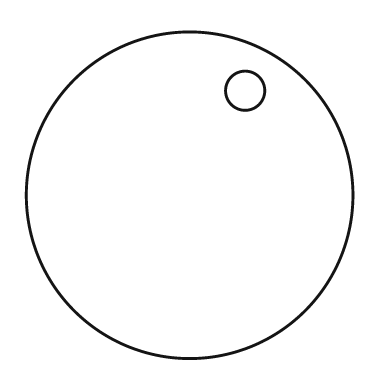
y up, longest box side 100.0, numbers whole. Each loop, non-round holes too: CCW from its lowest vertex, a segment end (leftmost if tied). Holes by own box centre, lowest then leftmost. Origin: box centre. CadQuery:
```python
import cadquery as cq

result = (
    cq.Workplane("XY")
    .moveTo(0.0, 0.0)
    .circle(50.0)
    .moveTo(17.0, 32.0)
    .circle(6.0)
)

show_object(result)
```